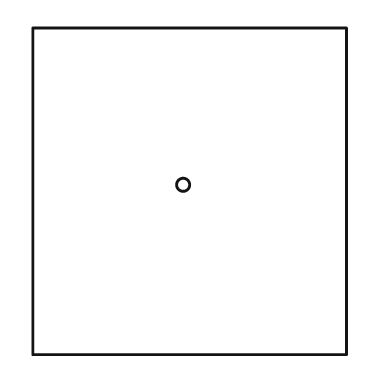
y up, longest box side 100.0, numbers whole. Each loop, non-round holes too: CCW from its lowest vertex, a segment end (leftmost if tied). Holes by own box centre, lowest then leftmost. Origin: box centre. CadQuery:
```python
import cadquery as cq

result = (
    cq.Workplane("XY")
    .moveTo(-48.0, -50.0)
    .lineTo(48.0, -50.0)
    .lineTo(48.0, 50.0)
    .lineTo(-48.0, 50.0)
    .close()
    .moveTo(-2.0, 2.0)
    .circle(2.0)
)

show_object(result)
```